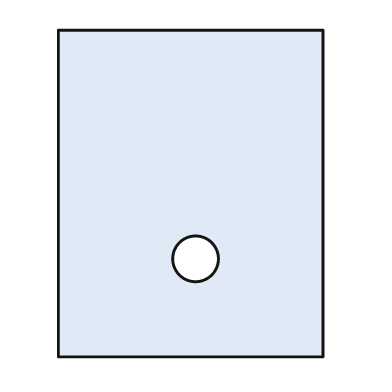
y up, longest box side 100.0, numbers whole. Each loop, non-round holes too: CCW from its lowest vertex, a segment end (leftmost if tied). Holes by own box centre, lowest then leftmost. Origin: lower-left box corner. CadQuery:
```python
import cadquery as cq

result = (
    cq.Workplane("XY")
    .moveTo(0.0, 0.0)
    .lineTo(81.0, 0.0)
    .lineTo(81.0, 100.0)
    .lineTo(0.0, 100.0)
    .close()
    .moveTo(42.0, 30.0)
    .circle(7.0)
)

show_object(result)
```